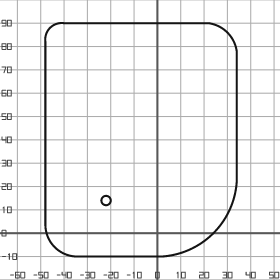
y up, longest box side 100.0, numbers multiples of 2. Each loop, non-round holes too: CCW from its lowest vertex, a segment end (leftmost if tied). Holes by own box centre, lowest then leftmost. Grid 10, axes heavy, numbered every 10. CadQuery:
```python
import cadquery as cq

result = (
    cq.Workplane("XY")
    .moveTo(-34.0, -10.0)
    .lineTo(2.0, -10.0)
    .threePointArc((24.0, 0.0), (34.0, 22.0))
    .lineTo(34.0, 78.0)
    .threePointArc((30.0, 86.0), (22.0, 90.0))
    .lineTo(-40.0, 90.0)
    .threePointArc((-46.0, 88.0), (-48.0, 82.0))
    .lineTo(-48.0, 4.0)
    .threePointArc((-44.0, -6.0), (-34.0, -10.0))
    .close()
    .moveTo(-22.0, 14.0)
    .circle(2.0)
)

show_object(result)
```